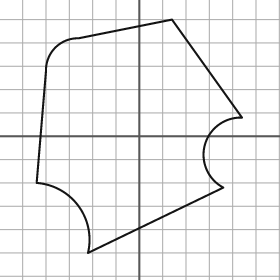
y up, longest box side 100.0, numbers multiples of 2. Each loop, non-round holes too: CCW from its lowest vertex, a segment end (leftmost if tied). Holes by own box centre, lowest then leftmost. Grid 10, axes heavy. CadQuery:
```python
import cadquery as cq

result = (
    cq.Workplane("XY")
    .moveTo(-22.0, -50.0)
    .lineTo(36.0, -22.0)
    .threePointArc((28.0, -4.0), (44.0, 8.0))
    .lineTo(14.0, 50.0)
    .lineTo(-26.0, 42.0)
    .threePointArc((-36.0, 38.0), (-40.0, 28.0))
    .lineTo(-44.0, -20.0)
    .threePointArc((-26.0, -30.0), (-22.0, -50.0))
    .close()
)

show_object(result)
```